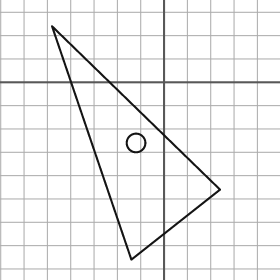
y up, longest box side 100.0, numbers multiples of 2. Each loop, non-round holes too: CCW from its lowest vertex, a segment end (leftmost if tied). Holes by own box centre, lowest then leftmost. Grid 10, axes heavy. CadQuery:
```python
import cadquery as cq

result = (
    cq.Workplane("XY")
    .moveTo(-14.0, -76.0)
    .lineTo(24.0, -46.0)
    .lineTo(-48.0, 24.0)
    .close()
    .moveTo(-12.0, -26.0)
    .circle(4.0)
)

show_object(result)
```